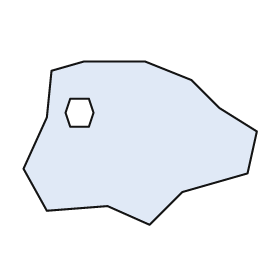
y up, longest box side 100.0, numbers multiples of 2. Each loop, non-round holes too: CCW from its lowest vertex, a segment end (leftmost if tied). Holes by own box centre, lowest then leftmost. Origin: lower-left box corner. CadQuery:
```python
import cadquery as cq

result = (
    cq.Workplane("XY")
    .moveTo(54.0, 0.0)
    .lineTo(68.0, 14.0)
    .lineTo(96.0, 22.0)
    .lineTo(100.0, 40.0)
    .lineTo(84.0, 50.0)
    .lineTo(72.0, 62.0)
    .lineTo(52.0, 70.0)
    .lineTo(26.0, 70.0)
    .lineTo(12.0, 66.0)
    .lineTo(10.0, 46.0)
    .lineTo(0.0, 24.0)
    .lineTo(10.0, 6.0)
    .lineTo(36.0, 8.0)
    .close()
    .moveTo(20.0, 42.0)
    .lineTo(28.0, 42.0)
    .lineTo(30.0, 48.0)
    .lineTo(28.0, 54.0)
    .lineTo(20.0, 54.0)
    .lineTo(18.0, 48.0)
    .close()
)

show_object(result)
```